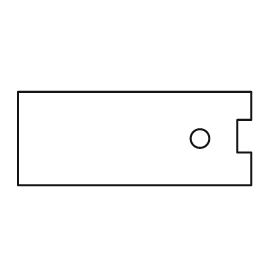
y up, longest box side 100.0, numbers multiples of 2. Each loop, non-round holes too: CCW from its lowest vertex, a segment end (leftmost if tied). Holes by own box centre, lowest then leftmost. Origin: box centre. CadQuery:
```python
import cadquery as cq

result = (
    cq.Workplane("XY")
    .moveTo(-50.0, -20.0)
    .lineTo(50.0, -20.0)
    .lineTo(50.0, -6.0)
    .lineTo(44.0, -6.0)
    .lineTo(44.0, 8.0)
    .lineTo(50.0, 8.0)
    .lineTo(50.0, 20.0)
    .lineTo(-50.0, 20.0)
    .close()
    .moveTo(28.0, 0.0)
    .circle(4.0)
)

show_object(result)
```